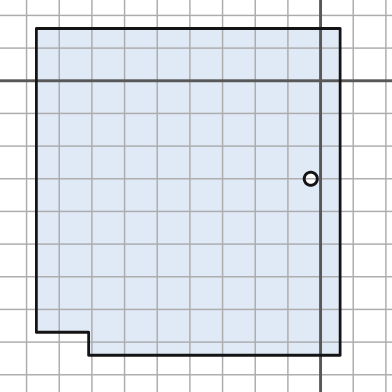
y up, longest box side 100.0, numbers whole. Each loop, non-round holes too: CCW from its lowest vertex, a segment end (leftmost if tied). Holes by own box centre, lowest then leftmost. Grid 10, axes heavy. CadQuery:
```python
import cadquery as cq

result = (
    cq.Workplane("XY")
    .moveTo(-71.0, -84.0)
    .lineTo(6.0, -84.0)
    .lineTo(6.0, 16.0)
    .lineTo(-87.0, 16.0)
    .lineTo(-87.0, -77.0)
    .lineTo(-71.0, -77.0)
    .close()
    .moveTo(-3.0, -30.0)
    .circle(2.0)
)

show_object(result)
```